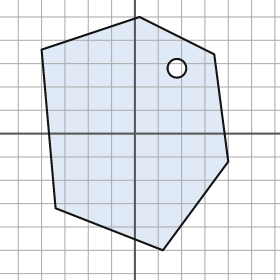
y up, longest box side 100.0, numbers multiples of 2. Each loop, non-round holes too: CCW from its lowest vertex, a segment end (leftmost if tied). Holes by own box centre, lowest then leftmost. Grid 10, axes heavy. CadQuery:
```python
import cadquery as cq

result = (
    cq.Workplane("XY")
    .moveTo(12.0, -50.0)
    .lineTo(40.0, -12.0)
    .lineTo(34.0, 34.0)
    .lineTo(2.0, 50.0)
    .lineTo(-40.0, 36.0)
    .lineTo(-34.0, -32.0)
    .close()
    .moveTo(18.0, 28.0)
    .circle(4.0)
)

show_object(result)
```